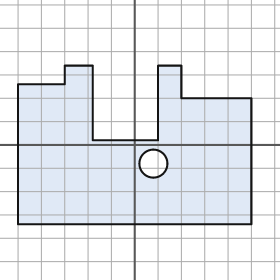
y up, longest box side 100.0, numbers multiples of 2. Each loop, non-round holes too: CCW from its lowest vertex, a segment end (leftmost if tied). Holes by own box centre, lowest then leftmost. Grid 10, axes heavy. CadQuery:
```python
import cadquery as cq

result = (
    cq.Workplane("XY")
    .moveTo(-50.0, -34.0)
    .lineTo(50.0, -34.0)
    .lineTo(50.0, 20.0)
    .lineTo(20.0, 20.0)
    .lineTo(20.0, 34.0)
    .lineTo(10.0, 34.0)
    .lineTo(10.0, 2.0)
    .lineTo(-18.0, 2.0)
    .lineTo(-18.0, 34.0)
    .lineTo(-30.0, 34.0)
    .lineTo(-30.0, 26.0)
    .lineTo(-50.0, 26.0)
    .close()
    .moveTo(8.0, -8.0)
    .circle(6.0)
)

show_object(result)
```